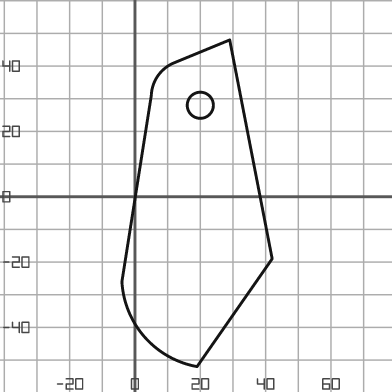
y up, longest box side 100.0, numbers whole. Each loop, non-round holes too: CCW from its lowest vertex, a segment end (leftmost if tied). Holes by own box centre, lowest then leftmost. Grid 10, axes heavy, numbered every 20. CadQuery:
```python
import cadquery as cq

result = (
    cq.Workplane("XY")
    .moveTo(19.0, -52.0)
    .lineTo(42.0, -19.0)
    .lineTo(29.0, 48.0)
    .lineTo(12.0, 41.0)
    .threePointArc((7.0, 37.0), (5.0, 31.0))
    .lineTo(-4.0, -26.0)
    .threePointArc((3.0, -43.0), (19.0, -52.0))
    .close()
    .moveTo(20.0, 28.0)
    .circle(4.0)
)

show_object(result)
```